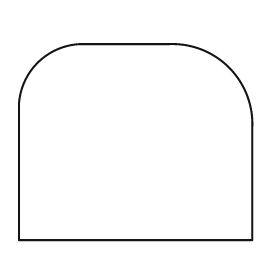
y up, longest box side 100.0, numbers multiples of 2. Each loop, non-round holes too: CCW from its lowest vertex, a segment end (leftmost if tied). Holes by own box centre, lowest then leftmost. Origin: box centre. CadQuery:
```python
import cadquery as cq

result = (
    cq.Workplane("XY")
    .moveTo(-50.0, -42.0)
    .lineTo(50.0, -42.0)
    .lineTo(50.0, 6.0)
    .threePointArc((40.0, 32.0), (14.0, 42.0))
    .lineTo(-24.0, 42.0)
    .threePointArc((-42.0, 34.0), (-50.0, 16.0))
    .close()
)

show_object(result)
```